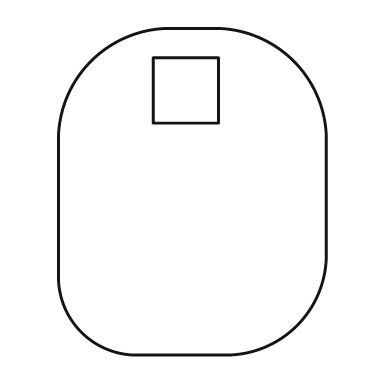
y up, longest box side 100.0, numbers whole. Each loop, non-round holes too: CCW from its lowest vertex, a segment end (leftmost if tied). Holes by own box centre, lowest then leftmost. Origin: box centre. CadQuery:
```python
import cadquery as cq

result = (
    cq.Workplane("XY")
    .moveTo(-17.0, -50.0)
    .lineTo(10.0, -50.0)
    .threePointArc((32.0, -41.0), (41.0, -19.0))
    .lineTo(41.0, 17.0)
    .threePointArc((31.0, 40.0), (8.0, 50.0))
    .lineTo(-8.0, 50.0)
    .threePointArc((-31.0, 40.0), (-41.0, 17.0))
    .lineTo(-41.0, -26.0)
    .threePointArc((-34.0, -43.0), (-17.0, -50.0))
    .close()
    .moveTo(-12.0, 21.0)
    .lineTo(8.0, 21.0)
    .lineTo(8.0, 41.0)
    .lineTo(-12.0, 41.0)
    .close()
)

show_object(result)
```